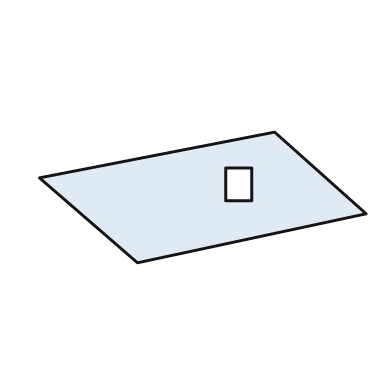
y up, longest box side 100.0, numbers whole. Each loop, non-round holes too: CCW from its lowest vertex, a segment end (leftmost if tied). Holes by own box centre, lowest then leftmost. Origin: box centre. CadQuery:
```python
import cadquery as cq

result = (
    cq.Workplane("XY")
    .moveTo(-20.0, -20.0)
    .lineTo(50.0, -5.0)
    .lineTo(22.0, 20.0)
    .lineTo(-50.0, 6.0)
    .close()
    .moveTo(7.0, -1.0)
    .lineTo(15.0, -1.0)
    .lineTo(15.0, 9.0)
    .lineTo(7.0, 9.0)
    .close()
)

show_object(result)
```